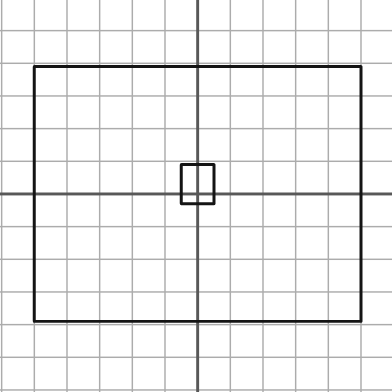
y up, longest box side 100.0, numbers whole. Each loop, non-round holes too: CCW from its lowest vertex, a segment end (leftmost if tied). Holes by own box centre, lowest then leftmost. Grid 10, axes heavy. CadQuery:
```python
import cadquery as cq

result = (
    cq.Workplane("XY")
    .moveTo(-50.0, -39.0)
    .lineTo(50.0, -39.0)
    .lineTo(50.0, 39.0)
    .lineTo(-50.0, 39.0)
    .close()
    .moveTo(-5.0, -3.0)
    .lineTo(5.0, -3.0)
    .lineTo(5.0, 9.0)
    .lineTo(-5.0, 9.0)
    .close()
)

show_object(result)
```